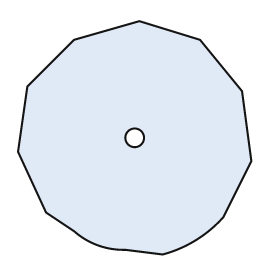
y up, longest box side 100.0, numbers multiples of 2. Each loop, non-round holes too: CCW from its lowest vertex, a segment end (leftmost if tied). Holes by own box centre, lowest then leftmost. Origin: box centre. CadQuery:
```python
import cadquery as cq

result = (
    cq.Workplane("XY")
    .moveTo(12.0, -50.0)
    .threePointArc((26.0, -44.0), (38.0, -34.0))
    .lineTo(50.0, -10.0)
    .lineTo(46.0, 20.0)
    .lineTo(28.0, 42.0)
    .lineTo(2.0, 50.0)
    .lineTo(-26.0, 42.0)
    .lineTo(-46.0, 22.0)
    .lineTo(-50.0, -6.0)
    .lineTo(-38.0, -32.0)
    .lineTo(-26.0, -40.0)
    .threePointArc((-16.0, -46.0), (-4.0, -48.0))
    .close()
    .moveTo(0.0, 0.0)
    .circle(4.0)
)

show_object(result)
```